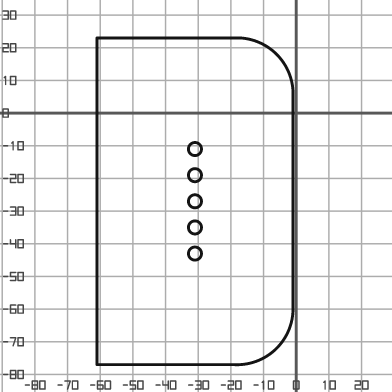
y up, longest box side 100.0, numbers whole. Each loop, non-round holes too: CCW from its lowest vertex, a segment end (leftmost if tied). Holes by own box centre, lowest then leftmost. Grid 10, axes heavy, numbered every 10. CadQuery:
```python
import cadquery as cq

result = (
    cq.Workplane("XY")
    .moveTo(-61.0, -77.0)
    .lineTo(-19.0, -77.0)
    .threePointArc((-6.0, -72.0), (-1.0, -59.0))
    .lineTo(-1.0, 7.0)
    .threePointArc((-6.0, 18.0), (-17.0, 23.0))
    .lineTo(-61.0, 23.0)
    .close()
    .moveTo(-31.0, -43.0)
    .circle(2.0)
    .moveTo(-31.0, -35.0)
    .circle(2.0)
    .moveTo(-31.0, -27.0)
    .circle(2.0)
    .moveTo(-31.0, -19.0)
    .circle(2.0)
    .moveTo(-31.0, -11.0)
    .circle(2.0)
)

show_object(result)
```